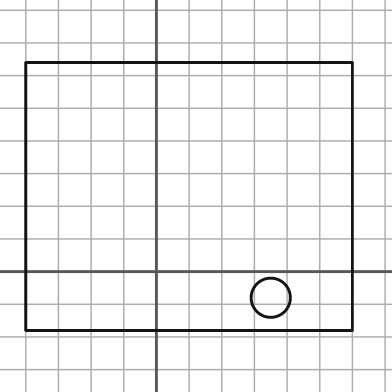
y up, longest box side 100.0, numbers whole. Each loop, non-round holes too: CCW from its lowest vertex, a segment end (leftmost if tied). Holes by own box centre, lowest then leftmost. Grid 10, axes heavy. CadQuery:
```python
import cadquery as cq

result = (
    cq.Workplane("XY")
    .moveTo(-40.0, -18.0)
    .lineTo(60.0, -18.0)
    .lineTo(60.0, 64.0)
    .lineTo(-40.0, 64.0)
    .close()
    .moveTo(35.0, -8.0)
    .circle(6.0)
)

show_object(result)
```